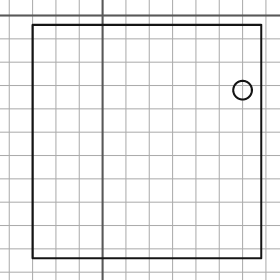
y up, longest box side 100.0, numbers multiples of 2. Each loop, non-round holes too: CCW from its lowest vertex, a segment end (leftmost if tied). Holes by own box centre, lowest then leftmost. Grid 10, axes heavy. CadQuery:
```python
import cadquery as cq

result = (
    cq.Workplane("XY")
    .moveTo(-30.0, -104.0)
    .lineTo(68.0, -104.0)
    .lineTo(68.0, -4.0)
    .lineTo(-30.0, -4.0)
    .close()
    .moveTo(60.0, -32.0)
    .circle(4.0)
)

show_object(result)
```